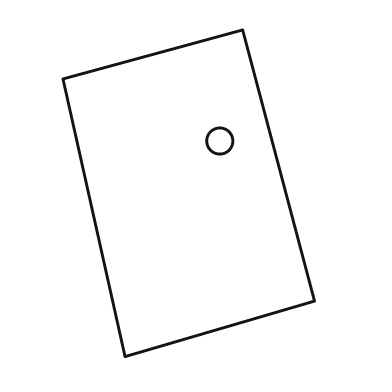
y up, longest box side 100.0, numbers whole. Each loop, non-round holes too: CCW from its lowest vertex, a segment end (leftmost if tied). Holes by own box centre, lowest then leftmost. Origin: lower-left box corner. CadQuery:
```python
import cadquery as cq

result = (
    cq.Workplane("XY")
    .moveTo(19.0, 0.0)
    .lineTo(77.0, 17.0)
    .lineTo(55.0, 100.0)
    .lineTo(0.0, 85.0)
    .close()
    .moveTo(48.0, 66.0)
    .circle(4.0)
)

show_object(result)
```